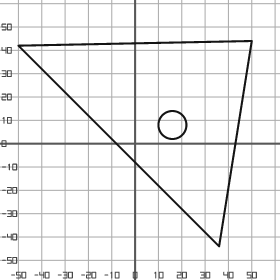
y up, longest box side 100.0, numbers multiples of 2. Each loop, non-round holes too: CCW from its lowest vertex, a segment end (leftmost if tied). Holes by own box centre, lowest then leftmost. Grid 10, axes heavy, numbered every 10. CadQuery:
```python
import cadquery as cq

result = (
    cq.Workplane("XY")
    .moveTo(36.0, -44.0)
    .lineTo(50.0, 44.0)
    .lineTo(-50.0, 42.0)
    .close()
    .moveTo(16.0, 8.0)
    .circle(6.0)
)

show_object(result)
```